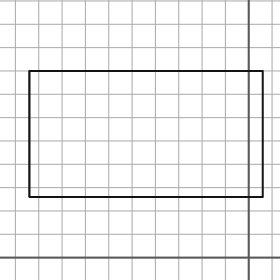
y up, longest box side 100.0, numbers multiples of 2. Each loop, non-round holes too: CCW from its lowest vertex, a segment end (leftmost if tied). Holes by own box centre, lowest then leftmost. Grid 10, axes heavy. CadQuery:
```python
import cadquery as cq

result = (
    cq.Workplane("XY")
    .moveTo(-94.0, 26.0)
    .lineTo(6.0, 26.0)
    .lineTo(6.0, 80.0)
    .lineTo(-94.0, 80.0)
    .close()
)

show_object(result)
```